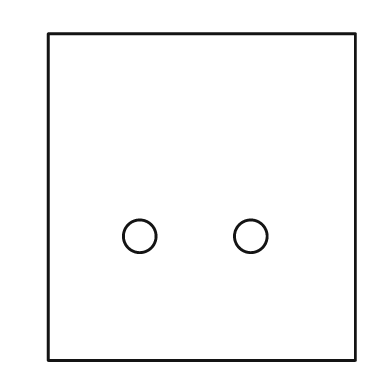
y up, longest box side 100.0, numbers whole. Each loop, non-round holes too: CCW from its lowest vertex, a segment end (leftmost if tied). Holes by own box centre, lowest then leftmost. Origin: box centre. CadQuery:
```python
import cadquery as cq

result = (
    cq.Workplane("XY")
    .moveTo(-47.0, -50.0)
    .lineTo(47.0, -50.0)
    .lineTo(47.0, 50.0)
    .lineTo(-47.0, 50.0)
    .close()
    .moveTo(-19.0, -12.0)
    .circle(5.0)
    .moveTo(15.0, -12.0)
    .circle(5.0)
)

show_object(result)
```